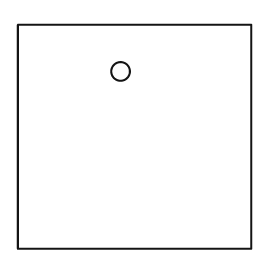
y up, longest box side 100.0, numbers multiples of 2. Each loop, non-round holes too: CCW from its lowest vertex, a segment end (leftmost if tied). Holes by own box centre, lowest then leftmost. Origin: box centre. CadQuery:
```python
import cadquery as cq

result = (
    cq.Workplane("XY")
    .moveTo(-50.0, -48.0)
    .lineTo(50.0, -48.0)
    .lineTo(50.0, 48.0)
    .lineTo(-50.0, 48.0)
    .close()
    .moveTo(-6.0, 28.0)
    .circle(4.0)
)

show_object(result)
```